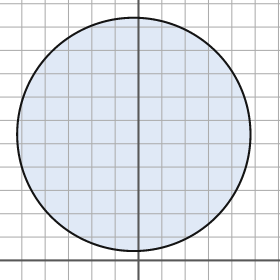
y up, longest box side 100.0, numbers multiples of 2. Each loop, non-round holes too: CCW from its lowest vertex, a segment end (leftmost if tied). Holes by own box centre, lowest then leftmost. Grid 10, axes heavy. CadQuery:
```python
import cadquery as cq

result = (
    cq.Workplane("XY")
    .moveTo(-2.0, 54.0)
    .circle(50.0)
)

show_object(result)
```